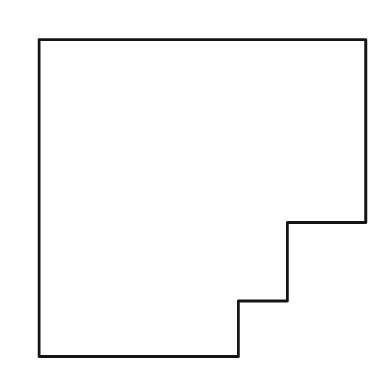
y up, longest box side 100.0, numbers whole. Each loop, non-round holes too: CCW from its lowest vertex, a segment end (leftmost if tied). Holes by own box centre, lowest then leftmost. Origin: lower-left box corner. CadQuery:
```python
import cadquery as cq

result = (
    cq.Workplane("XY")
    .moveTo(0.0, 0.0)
    .lineTo(61.0, 0.0)
    .lineTo(61.0, 17.0)
    .lineTo(76.0, 17.0)
    .lineTo(76.0, 41.0)
    .lineTo(100.0, 41.0)
    .lineTo(100.0, 97.0)
    .lineTo(0.0, 97.0)
    .close()
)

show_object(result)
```